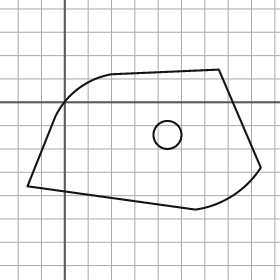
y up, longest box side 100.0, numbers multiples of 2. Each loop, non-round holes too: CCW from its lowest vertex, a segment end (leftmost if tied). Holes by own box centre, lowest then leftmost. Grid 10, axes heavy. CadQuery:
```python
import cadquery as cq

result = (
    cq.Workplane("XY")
    .moveTo(56.0, -46.0)
    .threePointArc((72.0, -40.0), (84.0, -28.0))
    .lineTo(66.0, 14.0)
    .lineTo(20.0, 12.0)
    .threePointArc((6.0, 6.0), (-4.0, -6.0))
    .lineTo(-16.0, -36.0)
    .close()
    .moveTo(44.0, -14.0)
    .circle(6.0)
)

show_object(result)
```